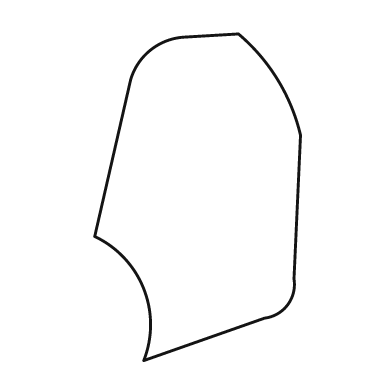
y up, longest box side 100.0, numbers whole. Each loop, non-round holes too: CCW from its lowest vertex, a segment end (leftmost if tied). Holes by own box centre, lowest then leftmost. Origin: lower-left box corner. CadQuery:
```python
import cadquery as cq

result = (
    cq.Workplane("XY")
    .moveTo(15.0, 0.0)
    .lineTo(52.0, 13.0)
    .threePointArc((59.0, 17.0), (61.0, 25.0))
    .lineTo(63.0, 69.0)
    .threePointArc((56.0, 86.0), (44.0, 100.0))
    .lineTo(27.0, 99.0)
    .threePointArc((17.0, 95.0), (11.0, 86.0))
    .lineTo(0.0, 38.0)
    .threePointArc((15.0, 22.0), (15.0, 0.0))
    .close()
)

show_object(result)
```